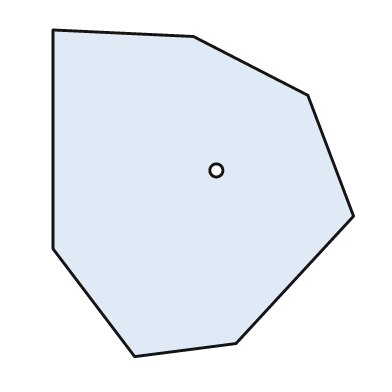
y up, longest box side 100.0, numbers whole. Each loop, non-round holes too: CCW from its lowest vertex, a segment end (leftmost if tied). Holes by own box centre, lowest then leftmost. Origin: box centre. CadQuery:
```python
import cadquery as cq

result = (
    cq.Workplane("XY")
    .moveTo(-21.0, -50.0)
    .lineTo(10.0, -46.0)
    .lineTo(46.0, -7.0)
    .lineTo(32.0, 30.0)
    .lineTo(-3.0, 48.0)
    .lineTo(-46.0, 50.0)
    .lineTo(-46.0, -17.0)
    .close()
    .moveTo(4.0, 7.0)
    .circle(2.0)
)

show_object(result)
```